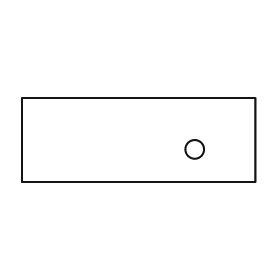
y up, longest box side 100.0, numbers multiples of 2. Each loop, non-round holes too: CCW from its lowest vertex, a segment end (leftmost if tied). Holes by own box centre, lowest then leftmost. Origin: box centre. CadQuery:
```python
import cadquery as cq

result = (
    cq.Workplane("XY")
    .moveTo(-50.0, -18.0)
    .lineTo(50.0, -18.0)
    .lineTo(50.0, 18.0)
    .lineTo(-50.0, 18.0)
    .close()
    .moveTo(24.0, -4.0)
    .circle(4.0)
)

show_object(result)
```